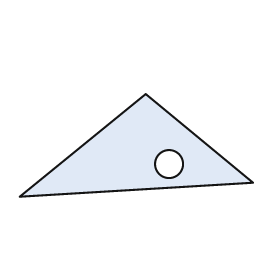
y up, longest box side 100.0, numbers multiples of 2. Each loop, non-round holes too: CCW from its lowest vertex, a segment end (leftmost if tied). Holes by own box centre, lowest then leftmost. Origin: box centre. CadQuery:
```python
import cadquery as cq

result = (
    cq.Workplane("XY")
    .moveTo(-50.0, -22.0)
    .lineTo(50.0, -16.0)
    .lineTo(4.0, 22.0)
    .close()
    .moveTo(14.0, -8.0)
    .circle(6.0)
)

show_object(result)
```